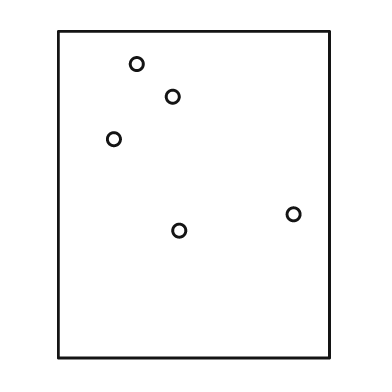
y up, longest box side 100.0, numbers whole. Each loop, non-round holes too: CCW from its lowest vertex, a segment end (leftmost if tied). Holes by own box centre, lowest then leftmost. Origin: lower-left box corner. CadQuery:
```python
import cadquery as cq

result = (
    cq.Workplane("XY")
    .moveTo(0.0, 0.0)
    .lineTo(83.0, 0.0)
    .lineTo(83.0, 100.0)
    .lineTo(0.0, 100.0)
    .close()
    .moveTo(37.0, 39.0)
    .circle(2.0)
    .moveTo(72.0, 44.0)
    .circle(2.0)
    .moveTo(17.0, 67.0)
    .circle(2.0)
    .moveTo(35.0, 80.0)
    .circle(2.0)
    .moveTo(24.0, 90.0)
    .circle(2.0)
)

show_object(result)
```